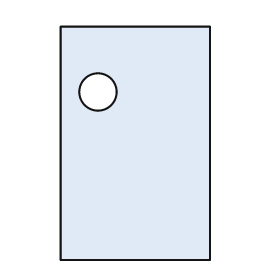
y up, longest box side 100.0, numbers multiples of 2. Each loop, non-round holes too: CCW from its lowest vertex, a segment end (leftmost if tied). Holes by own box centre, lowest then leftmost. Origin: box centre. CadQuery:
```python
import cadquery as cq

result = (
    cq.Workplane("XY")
    .moveTo(-32.0, -50.0)
    .lineTo(32.0, -50.0)
    .lineTo(32.0, 50.0)
    .lineTo(-32.0, 50.0)
    .close()
    .moveTo(-16.0, 22.0)
    .circle(8.0)
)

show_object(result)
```